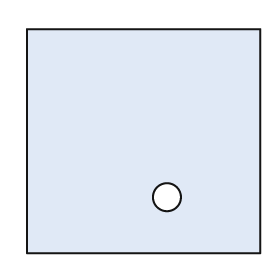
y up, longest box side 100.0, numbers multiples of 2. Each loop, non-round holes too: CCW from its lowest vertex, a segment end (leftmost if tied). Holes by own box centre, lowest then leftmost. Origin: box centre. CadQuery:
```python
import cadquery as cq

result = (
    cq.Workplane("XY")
    .moveTo(-50.0, -48.0)
    .lineTo(50.0, -48.0)
    .lineTo(50.0, 48.0)
    .lineTo(-50.0, 48.0)
    .close()
    .moveTo(10.0, -24.0)
    .circle(6.0)
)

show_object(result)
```